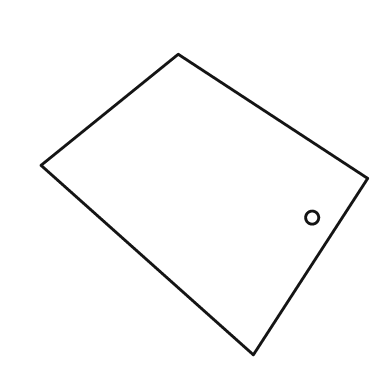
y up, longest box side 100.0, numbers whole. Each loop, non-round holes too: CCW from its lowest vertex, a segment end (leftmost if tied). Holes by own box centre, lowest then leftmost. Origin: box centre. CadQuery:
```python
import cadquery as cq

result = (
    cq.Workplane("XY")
    .moveTo(15.0, -46.0)
    .lineTo(50.0, 8.0)
    .lineTo(-8.0, 46.0)
    .lineTo(-50.0, 12.0)
    .close()
    .moveTo(33.0, -4.0)
    .circle(2.0)
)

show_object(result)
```